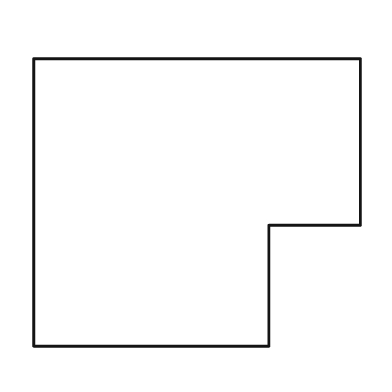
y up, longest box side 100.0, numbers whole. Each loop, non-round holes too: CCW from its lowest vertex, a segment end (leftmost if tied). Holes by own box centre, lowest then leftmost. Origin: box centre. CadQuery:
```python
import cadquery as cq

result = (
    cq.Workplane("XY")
    .moveTo(-50.0, -44.0)
    .lineTo(22.0, -44.0)
    .lineTo(22.0, -7.0)
    .lineTo(50.0, -7.0)
    .lineTo(50.0, 44.0)
    .lineTo(-50.0, 44.0)
    .close()
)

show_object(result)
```